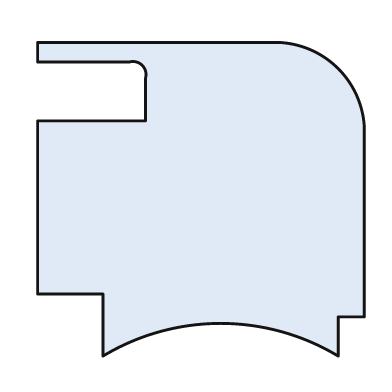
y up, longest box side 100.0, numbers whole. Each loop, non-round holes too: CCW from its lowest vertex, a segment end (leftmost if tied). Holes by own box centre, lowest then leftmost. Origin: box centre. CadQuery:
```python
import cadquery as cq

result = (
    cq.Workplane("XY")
    .moveTo(-30.0, -48.0)
    .threePointArc((6.0, -38.0), (42.0, -48.0))
    .lineTo(42.0, -36.0)
    .lineTo(50.0, -36.0)
    .lineTo(50.0, 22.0)
    .threePointArc((42.0, 40.0), (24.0, 48.0))
    .lineTo(-50.0, 48.0)
    .lineTo(-50.0, 42.0)
    .lineTo(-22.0, 42.0)
    .threePointArc((-18.0, 41.0), (-17.0, 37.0))
    .lineTo(-17.0, 24.0)
    .lineTo(-50.0, 24.0)
    .lineTo(-50.0, -29.0)
    .lineTo(-30.0, -29.0)
    .close()
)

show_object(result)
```